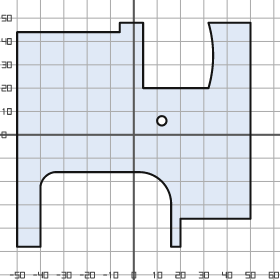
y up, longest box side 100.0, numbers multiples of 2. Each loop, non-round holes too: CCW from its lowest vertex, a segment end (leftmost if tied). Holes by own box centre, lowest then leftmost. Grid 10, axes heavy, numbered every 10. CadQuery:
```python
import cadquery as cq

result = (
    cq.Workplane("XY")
    .moveTo(-50.0, -48.0)
    .lineTo(-40.0, -48.0)
    .lineTo(-40.0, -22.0)
    .threePointArc((-38.0, -18.0), (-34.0, -16.0))
    .lineTo(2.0, -16.0)
    .threePointArc((12.0, -20.0), (16.0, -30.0))
    .lineTo(16.0, -48.0)
    .lineTo(20.0, -48.0)
    .lineTo(20.0, -36.0)
    .lineTo(50.0, -36.0)
    .lineTo(50.0, 48.0)
    .lineTo(32.0, 48.0)
    .threePointArc((34.0, 34.0), (32.0, 20.0))
    .lineTo(4.0, 20.0)
    .lineTo(4.0, 48.0)
    .lineTo(-6.0, 48.0)
    .lineTo(-6.0, 44.0)
    .lineTo(-50.0, 44.0)
    .close()
    .moveTo(12.0, 6.0)
    .circle(2.0)
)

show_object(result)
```